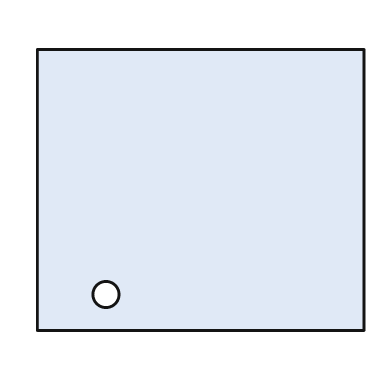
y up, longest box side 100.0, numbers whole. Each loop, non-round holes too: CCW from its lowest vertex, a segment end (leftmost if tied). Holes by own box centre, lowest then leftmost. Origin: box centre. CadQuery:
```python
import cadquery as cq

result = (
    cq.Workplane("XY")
    .moveTo(-50.0, -43.0)
    .lineTo(50.0, -43.0)
    .lineTo(50.0, 43.0)
    .lineTo(-50.0, 43.0)
    .close()
    .moveTo(-29.0, -32.0)
    .circle(4.0)
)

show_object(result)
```